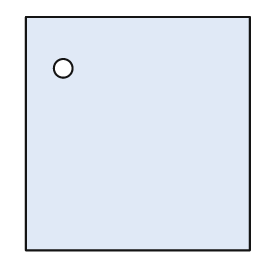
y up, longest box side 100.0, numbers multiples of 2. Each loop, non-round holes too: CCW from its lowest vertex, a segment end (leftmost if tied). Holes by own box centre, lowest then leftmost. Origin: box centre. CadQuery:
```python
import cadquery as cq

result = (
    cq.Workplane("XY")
    .moveTo(-48.0, -50.0)
    .lineTo(48.0, -50.0)
    .lineTo(48.0, 50.0)
    .lineTo(-48.0, 50.0)
    .close()
    .moveTo(-32.0, 28.0)
    .circle(4.0)
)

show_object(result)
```